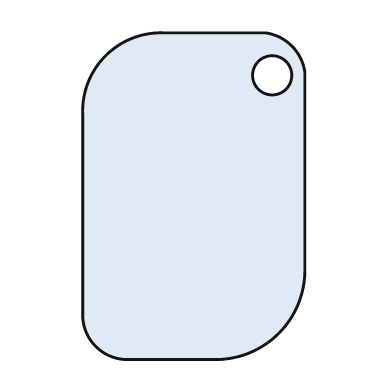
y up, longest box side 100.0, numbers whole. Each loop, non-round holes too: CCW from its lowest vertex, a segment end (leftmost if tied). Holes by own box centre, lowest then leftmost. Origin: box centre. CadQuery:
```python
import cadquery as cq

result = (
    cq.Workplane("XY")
    .moveTo(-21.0, -50.0)
    .lineTo(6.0, -50.0)
    .threePointArc((26.0, -42.0), (34.0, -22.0))
    .lineTo(34.0, 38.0)
    .threePointArc((30.0, 46.0), (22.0, 50.0))
    .lineTo(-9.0, 50.0)
    .threePointArc((-27.0, 43.0), (-34.0, 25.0))
    .lineTo(-34.0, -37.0)
    .threePointArc((-30.0, -46.0), (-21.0, -50.0))
    .close()
    .moveTo(24.0, 37.0)
    .circle(6.0)
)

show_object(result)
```